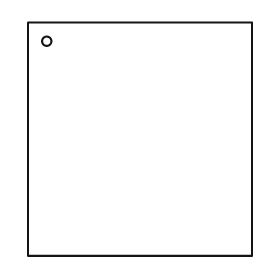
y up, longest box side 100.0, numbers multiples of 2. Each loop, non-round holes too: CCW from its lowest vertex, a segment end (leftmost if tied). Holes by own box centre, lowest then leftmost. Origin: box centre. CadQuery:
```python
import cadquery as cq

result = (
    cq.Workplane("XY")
    .moveTo(-48.0, -50.0)
    .lineTo(48.0, -50.0)
    .lineTo(48.0, 50.0)
    .lineTo(-48.0, 50.0)
    .close()
    .moveTo(-40.0, 42.0)
    .circle(2.0)
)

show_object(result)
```